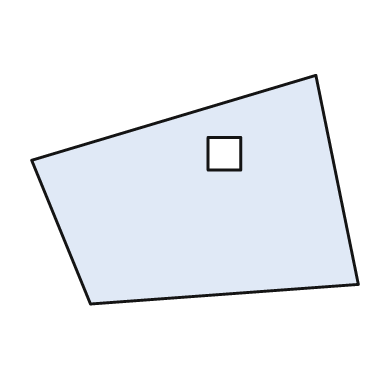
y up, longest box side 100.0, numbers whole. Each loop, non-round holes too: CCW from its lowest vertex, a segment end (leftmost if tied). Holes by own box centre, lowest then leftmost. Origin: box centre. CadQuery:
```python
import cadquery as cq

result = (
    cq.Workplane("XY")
    .moveTo(-32.0, -35.0)
    .lineTo(50.0, -29.0)
    .lineTo(37.0, 35.0)
    .lineTo(-50.0, 9.0)
    .close()
    .moveTo(4.0, 6.0)
    .lineTo(14.0, 6.0)
    .lineTo(14.0, 16.0)
    .lineTo(4.0, 16.0)
    .close()
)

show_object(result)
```